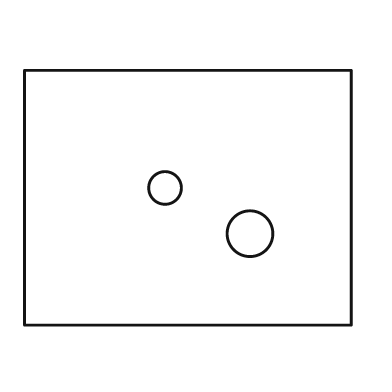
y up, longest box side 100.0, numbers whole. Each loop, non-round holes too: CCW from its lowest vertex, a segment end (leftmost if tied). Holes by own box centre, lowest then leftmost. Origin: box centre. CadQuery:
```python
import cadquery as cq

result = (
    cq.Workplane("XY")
    .moveTo(-50.0, -39.0)
    .lineTo(50.0, -39.0)
    .lineTo(50.0, 39.0)
    .lineTo(-50.0, 39.0)
    .close()
    .moveTo(19.0, -11.0)
    .circle(7.0)
    .moveTo(-7.0, 3.0)
    .circle(5.0)
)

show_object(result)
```